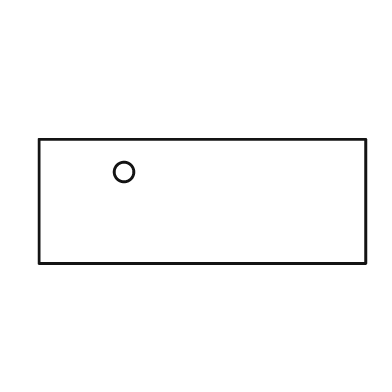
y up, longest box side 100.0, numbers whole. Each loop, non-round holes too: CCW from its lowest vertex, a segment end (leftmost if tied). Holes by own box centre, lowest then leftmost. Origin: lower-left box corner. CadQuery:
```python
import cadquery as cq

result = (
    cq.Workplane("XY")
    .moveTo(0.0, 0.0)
    .lineTo(100.0, 0.0)
    .lineTo(100.0, 38.0)
    .lineTo(0.0, 38.0)
    .close()
    .moveTo(26.0, 28.0)
    .circle(3.0)
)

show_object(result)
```